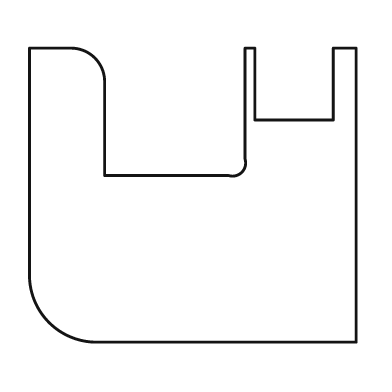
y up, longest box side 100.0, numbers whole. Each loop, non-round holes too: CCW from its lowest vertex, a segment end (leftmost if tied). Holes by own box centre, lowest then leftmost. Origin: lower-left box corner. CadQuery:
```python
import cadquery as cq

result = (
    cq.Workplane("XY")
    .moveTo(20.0, 0.0)
    .lineTo(100.0, 0.0)
    .lineTo(100.0, 90.0)
    .lineTo(93.0, 90.0)
    .lineTo(93.0, 68.0)
    .lineTo(69.0, 68.0)
    .lineTo(69.0, 90.0)
    .lineTo(66.0, 90.0)
    .lineTo(66.0, 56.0)
    .threePointArc((65.0, 52.0), (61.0, 51.0))
    .lineTo(23.0, 51.0)
    .lineTo(23.0, 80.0)
    .threePointArc((20.0, 87.0), (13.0, 90.0))
    .lineTo(0.0, 90.0)
    .lineTo(0.0, 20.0)
    .threePointArc((6.0, 6.0), (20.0, 0.0))
    .close()
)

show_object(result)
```